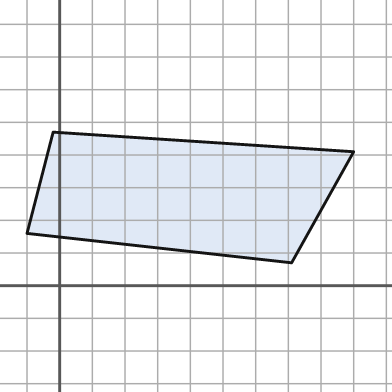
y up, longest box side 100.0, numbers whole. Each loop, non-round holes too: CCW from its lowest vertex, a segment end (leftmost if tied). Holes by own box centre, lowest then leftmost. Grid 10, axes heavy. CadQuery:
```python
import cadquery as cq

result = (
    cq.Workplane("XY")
    .moveTo(71.0, 7.0)
    .lineTo(90.0, 41.0)
    .lineTo(-2.0, 47.0)
    .lineTo(-10.0, 16.0)
    .close()
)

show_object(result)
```